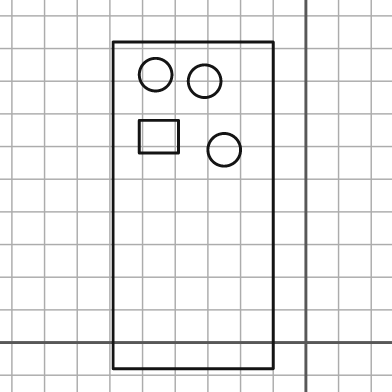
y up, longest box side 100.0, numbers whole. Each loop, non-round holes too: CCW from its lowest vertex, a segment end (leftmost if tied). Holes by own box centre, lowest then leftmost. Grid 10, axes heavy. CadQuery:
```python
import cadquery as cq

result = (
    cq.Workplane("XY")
    .moveTo(-59.0, -8.0)
    .lineTo(-10.0, -8.0)
    .lineTo(-10.0, 92.0)
    .lineTo(-59.0, 92.0)
    .close()
    .moveTo(-25.0, 59.0)
    .circle(5.0)
    .moveTo(-51.0, 58.0)
    .lineTo(-39.0, 58.0)
    .lineTo(-39.0, 68.0)
    .lineTo(-51.0, 68.0)
    .close()
    .moveTo(-31.0, 80.0)
    .circle(5.0)
    .moveTo(-46.0, 82.0)
    .circle(5.0)
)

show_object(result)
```